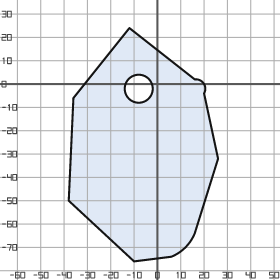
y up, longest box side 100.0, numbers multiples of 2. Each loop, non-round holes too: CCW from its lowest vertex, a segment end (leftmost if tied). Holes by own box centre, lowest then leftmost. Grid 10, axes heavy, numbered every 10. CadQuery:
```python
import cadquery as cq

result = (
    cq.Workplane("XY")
    .moveTo(-10.0, -76.0)
    .lineTo(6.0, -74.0)
    .threePointArc((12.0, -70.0), (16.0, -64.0))
    .lineTo(26.0, -32.0)
    .lineTo(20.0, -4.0)
    .threePointArc((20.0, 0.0), (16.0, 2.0))
    .lineTo(-12.0, 24.0)
    .lineTo(-36.0, -6.0)
    .lineTo(-38.0, -50.0)
    .close()
    .moveTo(-8.0, -2.0)
    .circle(6.0)
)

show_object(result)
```